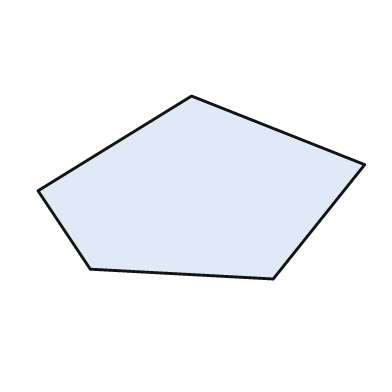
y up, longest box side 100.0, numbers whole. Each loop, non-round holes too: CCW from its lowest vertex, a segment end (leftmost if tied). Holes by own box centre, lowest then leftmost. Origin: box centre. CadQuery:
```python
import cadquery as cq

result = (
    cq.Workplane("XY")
    .moveTo(22.0, -28.0)
    .lineTo(50.0, 7.0)
    .lineTo(-3.0, 28.0)
    .lineTo(-50.0, -1.0)
    .lineTo(-34.0, -25.0)
    .close()
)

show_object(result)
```